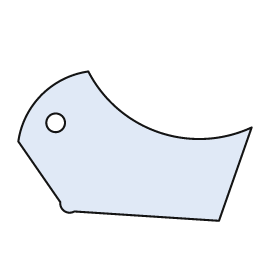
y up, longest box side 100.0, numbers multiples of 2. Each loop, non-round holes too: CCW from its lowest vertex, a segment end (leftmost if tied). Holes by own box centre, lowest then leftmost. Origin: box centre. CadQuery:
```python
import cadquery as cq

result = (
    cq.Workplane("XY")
    .moveTo(36.0, -32.0)
    .lineTo(50.0, 8.0)
    .threePointArc((10.0, 6.0), (-20.0, 32.0))
    .threePointArc((-40.0, 22.0), (-50.0, 2.0))
    .lineTo(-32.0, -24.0)
    .threePointArc((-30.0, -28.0), (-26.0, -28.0))
    .close()
    .moveTo(-34.0, 10.0)
    .circle(4.0)
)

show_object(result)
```